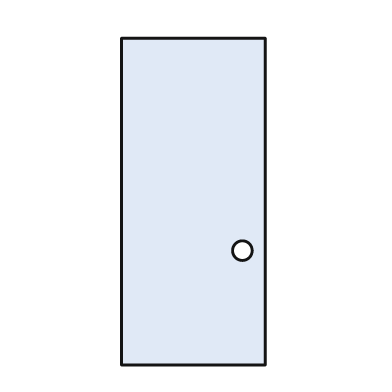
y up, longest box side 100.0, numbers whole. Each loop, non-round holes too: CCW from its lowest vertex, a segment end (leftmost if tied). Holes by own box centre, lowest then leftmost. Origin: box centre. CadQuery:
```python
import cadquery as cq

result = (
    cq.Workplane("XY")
    .moveTo(-22.0, -50.0)
    .lineTo(22.0, -50.0)
    .lineTo(22.0, 50.0)
    .lineTo(-22.0, 50.0)
    .close()
    .moveTo(15.0, -15.0)
    .circle(3.0)
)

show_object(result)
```